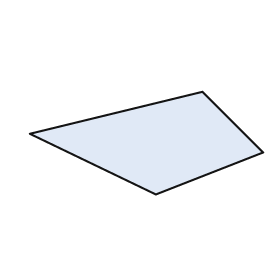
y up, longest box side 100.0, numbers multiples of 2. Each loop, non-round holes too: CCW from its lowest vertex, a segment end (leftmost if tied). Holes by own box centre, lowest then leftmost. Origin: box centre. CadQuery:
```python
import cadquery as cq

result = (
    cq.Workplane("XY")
    .moveTo(4.0, -22.0)
    .lineTo(50.0, -4.0)
    .lineTo(24.0, 22.0)
    .lineTo(-50.0, 4.0)
    .close()
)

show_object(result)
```